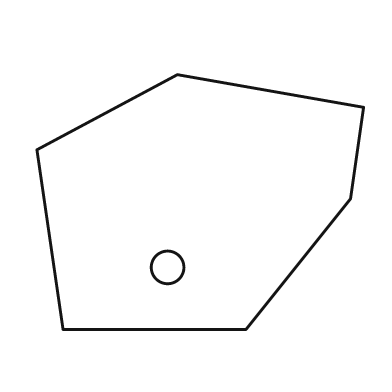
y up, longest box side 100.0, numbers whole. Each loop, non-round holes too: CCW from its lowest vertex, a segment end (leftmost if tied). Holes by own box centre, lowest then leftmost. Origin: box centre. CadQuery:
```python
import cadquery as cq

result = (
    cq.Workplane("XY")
    .moveTo(-42.0, -39.0)
    .lineTo(14.0, -39.0)
    .lineTo(46.0, 1.0)
    .lineTo(50.0, 29.0)
    .lineTo(-7.0, 39.0)
    .lineTo(-50.0, 16.0)
    .close()
    .moveTo(-10.0, -20.0)
    .circle(5.0)
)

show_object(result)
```